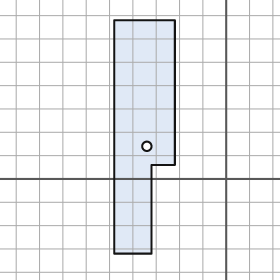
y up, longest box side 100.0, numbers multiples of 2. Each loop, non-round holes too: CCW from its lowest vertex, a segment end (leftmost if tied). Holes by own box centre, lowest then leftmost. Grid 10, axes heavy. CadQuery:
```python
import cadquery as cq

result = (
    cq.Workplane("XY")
    .moveTo(-48.0, -32.0)
    .lineTo(-32.0, -32.0)
    .lineTo(-32.0, 6.0)
    .lineTo(-22.0, 6.0)
    .lineTo(-22.0, 68.0)
    .lineTo(-48.0, 68.0)
    .close()
    .moveTo(-34.0, 14.0)
    .circle(2.0)
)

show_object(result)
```